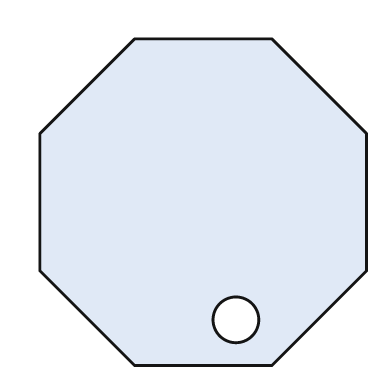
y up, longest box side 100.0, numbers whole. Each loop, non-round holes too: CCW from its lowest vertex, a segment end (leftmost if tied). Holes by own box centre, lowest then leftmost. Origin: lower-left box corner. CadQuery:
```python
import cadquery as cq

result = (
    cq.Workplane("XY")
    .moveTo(29.0, 0.0)
    .lineTo(71.0, 0.0)
    .lineTo(100.0, 29.0)
    .lineTo(100.0, 71.0)
    .lineTo(71.0, 100.0)
    .lineTo(29.0, 100.0)
    .lineTo(0.0, 71.0)
    .lineTo(0.0, 29.0)
    .close()
    .moveTo(60.0, 14.0)
    .circle(7.0)
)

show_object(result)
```